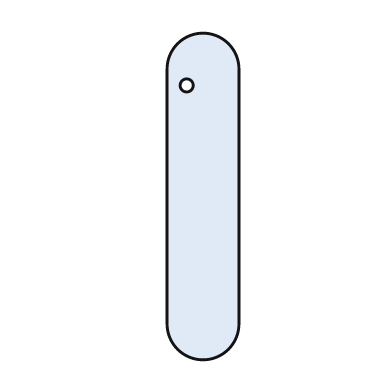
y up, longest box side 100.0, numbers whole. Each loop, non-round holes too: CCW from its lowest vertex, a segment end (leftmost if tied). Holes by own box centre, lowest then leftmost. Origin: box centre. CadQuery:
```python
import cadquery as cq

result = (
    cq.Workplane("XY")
    .moveTo(-11.0, -39.0)
    .threePointArc((0.0, -50.0), (11.0, -39.0))
    .lineTo(11.0, 39.0)
    .threePointArc((0.0, 50.0), (-11.0, 39.0))
    .close()
    .moveTo(-5.0, 34.0)
    .circle(2.0)
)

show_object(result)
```